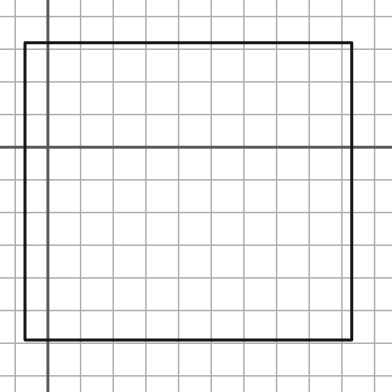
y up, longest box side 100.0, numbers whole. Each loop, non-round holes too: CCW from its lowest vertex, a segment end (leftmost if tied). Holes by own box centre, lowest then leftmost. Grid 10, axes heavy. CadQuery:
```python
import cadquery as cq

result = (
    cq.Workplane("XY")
    .moveTo(-7.0, -59.0)
    .lineTo(93.0, -59.0)
    .lineTo(93.0, 32.0)
    .lineTo(-7.0, 32.0)
    .close()
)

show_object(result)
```